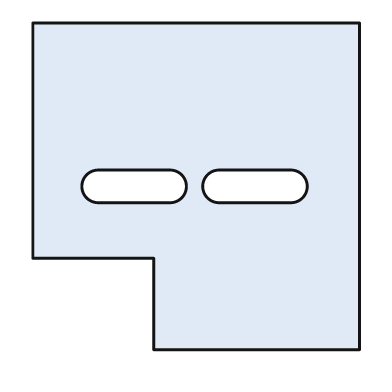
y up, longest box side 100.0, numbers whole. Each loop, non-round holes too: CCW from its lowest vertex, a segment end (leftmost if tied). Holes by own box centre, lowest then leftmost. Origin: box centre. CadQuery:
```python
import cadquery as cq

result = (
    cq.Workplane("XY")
    .moveTo(-13.0, -50.0)
    .lineTo(50.0, -50.0)
    .lineTo(50.0, 50.0)
    .lineTo(-50.0, 50.0)
    .lineTo(-50.0, -22.0)
    .lineTo(-13.0, -22.0)
    .close()
    .moveTo(-30.0, -5.0)
    .lineTo(-8.0, -5.0)
    .threePointArc((-3.0, 0.0), (-8.0, 5.0))
    .lineTo(-30.0, 5.0)
    .threePointArc((-35.0, 0.0), (-30.0, -5.0))
    .close()
    .moveTo(7.0, -5.0)
    .lineTo(29.0, -5.0)
    .threePointArc((34.0, 0.0), (29.0, 5.0))
    .lineTo(7.0, 5.0)
    .threePointArc((2.0, 0.0), (7.0, -5.0))
    .close()
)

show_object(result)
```